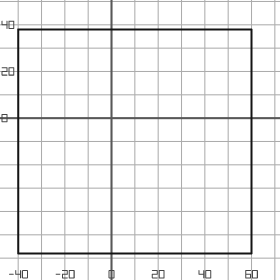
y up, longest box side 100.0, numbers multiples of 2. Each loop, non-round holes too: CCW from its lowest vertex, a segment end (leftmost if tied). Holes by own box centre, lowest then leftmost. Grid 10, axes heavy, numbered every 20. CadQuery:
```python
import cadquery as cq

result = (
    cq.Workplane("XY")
    .moveTo(-40.0, -58.0)
    .lineTo(60.0, -58.0)
    .lineTo(60.0, 38.0)
    .lineTo(-40.0, 38.0)
    .close()
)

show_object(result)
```